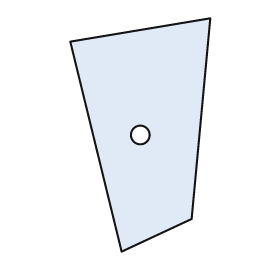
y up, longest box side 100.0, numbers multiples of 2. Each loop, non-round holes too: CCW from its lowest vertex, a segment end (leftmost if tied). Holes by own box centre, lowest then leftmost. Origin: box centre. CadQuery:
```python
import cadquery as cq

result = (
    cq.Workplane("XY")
    .moveTo(-8.0, -50.0)
    .lineTo(22.0, -36.0)
    .lineTo(30.0, 50.0)
    .lineTo(-30.0, 40.0)
    .close()
    .moveTo(0.0, 0.0)
    .circle(4.0)
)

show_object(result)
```